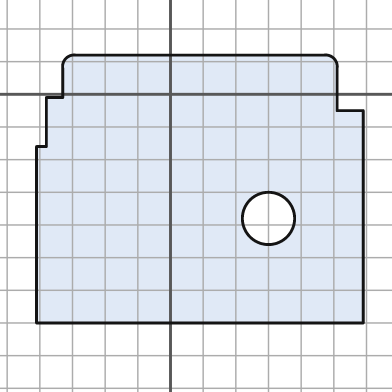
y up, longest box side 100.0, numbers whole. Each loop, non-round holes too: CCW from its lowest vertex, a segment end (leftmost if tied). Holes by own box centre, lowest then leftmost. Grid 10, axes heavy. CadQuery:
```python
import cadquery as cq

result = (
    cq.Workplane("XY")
    .moveTo(-41.0, -70.0)
    .lineTo(59.0, -70.0)
    .lineTo(59.0, -5.0)
    .lineTo(51.0, -5.0)
    .lineTo(51.0, 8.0)
    .threePointArc((50.0, 11.0), (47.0, 12.0))
    .lineTo(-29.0, 12.0)
    .threePointArc((-32.0, 11.0), (-33.0, 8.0))
    .lineTo(-33.0, -1.0)
    .lineTo(-38.0, -1.0)
    .lineTo(-38.0, -16.0)
    .lineTo(-41.0, -16.0)
    .close()
    .moveTo(30.0, -38.0)
    .circle(8.0)
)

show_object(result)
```